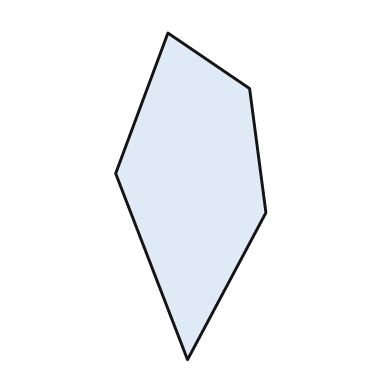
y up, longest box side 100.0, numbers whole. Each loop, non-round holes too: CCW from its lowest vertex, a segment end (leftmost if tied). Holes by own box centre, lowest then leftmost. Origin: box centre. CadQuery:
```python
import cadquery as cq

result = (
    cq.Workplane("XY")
    .moveTo(-1.0, -50.0)
    .lineTo(23.0, -5.0)
    .lineTo(18.0, 33.0)
    .lineTo(-7.0, 50.0)
    .lineTo(-23.0, 7.0)
    .close()
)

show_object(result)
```